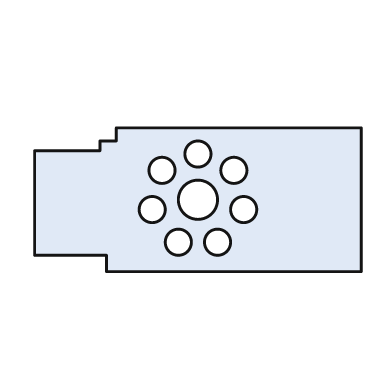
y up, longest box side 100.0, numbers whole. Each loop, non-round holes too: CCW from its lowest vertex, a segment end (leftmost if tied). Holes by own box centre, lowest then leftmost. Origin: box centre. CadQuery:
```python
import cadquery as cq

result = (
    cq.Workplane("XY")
    .moveTo(-28.0, -22.0)
    .lineTo(50.0, -22.0)
    .lineTo(50.0, 22.0)
    .lineTo(-25.0, 22.0)
    .lineTo(-25.0, 18.0)
    .lineTo(-30.0, 18.0)
    .lineTo(-30.0, 15.0)
    .lineTo(-50.0, 15.0)
    .lineTo(-50.0, -17.0)
    .lineTo(-28.0, -17.0)
    .close()
    .moveTo(-6.0, -13.0)
    .circle(4.0)
    .moveTo(6.0, -13.0)
    .circle(4.0)
    .moveTo(-14.0, -3.0)
    .circle(4.0)
    .moveTo(14.0, -3.0)
    .circle(4.0)
    .moveTo(0.0, 0.0)
    .circle(6.0)
    .moveTo(-11.0, 9.0)
    .circle(4.0)
    .moveTo(11.0, 9.0)
    .circle(4.0)
    .moveTo(0.0, 14.0)
    .circle(4.0)
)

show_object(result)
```